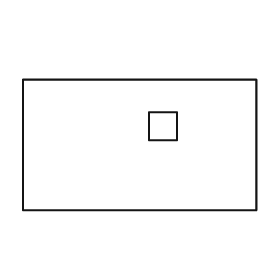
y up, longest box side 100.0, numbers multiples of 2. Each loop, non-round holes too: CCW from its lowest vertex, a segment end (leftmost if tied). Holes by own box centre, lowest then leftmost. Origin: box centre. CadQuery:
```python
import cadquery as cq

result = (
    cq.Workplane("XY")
    .moveTo(-50.0, -28.0)
    .lineTo(50.0, -28.0)
    .lineTo(50.0, 28.0)
    .lineTo(-50.0, 28.0)
    .close()
    .moveTo(4.0, 2.0)
    .lineTo(16.0, 2.0)
    .lineTo(16.0, 14.0)
    .lineTo(4.0, 14.0)
    .close()
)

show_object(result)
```